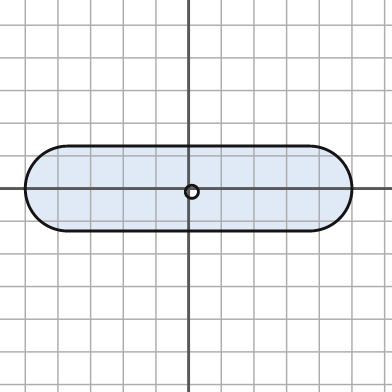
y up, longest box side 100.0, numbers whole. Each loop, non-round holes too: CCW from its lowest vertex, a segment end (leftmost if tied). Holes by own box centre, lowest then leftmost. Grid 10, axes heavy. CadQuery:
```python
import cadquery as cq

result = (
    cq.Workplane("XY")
    .moveTo(-37.0, -13.0)
    .lineTo(37.0, -13.0)
    .threePointArc((50.0, 0.0), (37.0, 13.0))
    .lineTo(-37.0, 13.0)
    .threePointArc((-50.0, 0.0), (-37.0, -13.0))
    .close()
    .moveTo(1.0, -1.0)
    .circle(2.0)
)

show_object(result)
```